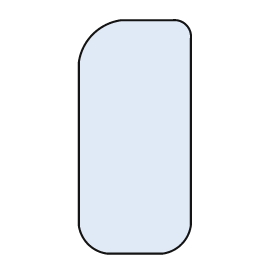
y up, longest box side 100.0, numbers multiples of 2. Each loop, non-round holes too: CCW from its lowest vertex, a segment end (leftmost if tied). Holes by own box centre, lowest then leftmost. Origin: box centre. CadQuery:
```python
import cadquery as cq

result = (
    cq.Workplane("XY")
    .moveTo(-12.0, -50.0)
    .lineTo(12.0, -50.0)
    .threePointArc((20.0, -46.0), (24.0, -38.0))
    .lineTo(24.0, 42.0)
    .threePointArc((22.0, 48.0), (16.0, 50.0))
    .lineTo(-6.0, 50.0)
    .threePointArc((-18.0, 44.0), (-24.0, 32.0))
    .lineTo(-24.0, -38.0)
    .threePointArc((-20.0, -46.0), (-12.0, -50.0))
    .close()
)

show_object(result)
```